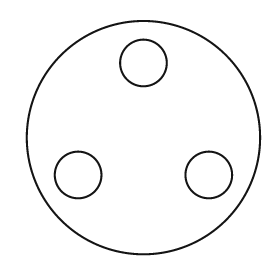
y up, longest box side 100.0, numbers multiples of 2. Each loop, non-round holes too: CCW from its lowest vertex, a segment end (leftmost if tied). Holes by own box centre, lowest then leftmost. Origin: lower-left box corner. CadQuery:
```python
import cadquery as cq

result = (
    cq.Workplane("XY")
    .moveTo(50.0, 50.0)
    .circle(50.0)
    .moveTo(22.0, 34.0)
    .circle(10.0)
    .moveTo(78.0, 34.0)
    .circle(10.0)
    .moveTo(50.0, 82.0)
    .circle(10.0)
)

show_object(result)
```